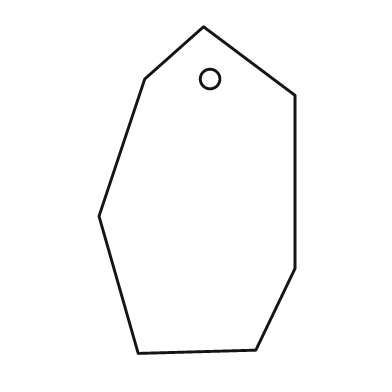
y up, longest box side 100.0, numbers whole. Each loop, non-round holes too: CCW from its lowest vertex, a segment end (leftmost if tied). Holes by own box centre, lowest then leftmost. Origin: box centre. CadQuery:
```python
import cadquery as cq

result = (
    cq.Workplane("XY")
    .moveTo(-18.0, -50.0)
    .lineTo(18.0, -49.0)
    .lineTo(30.0, -24.0)
    .lineTo(30.0, 29.0)
    .lineTo(2.0, 50.0)
    .lineTo(-16.0, 34.0)
    .lineTo(-30.0, -8.0)
    .close()
    .moveTo(4.0, 34.0)
    .circle(3.0)
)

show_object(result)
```